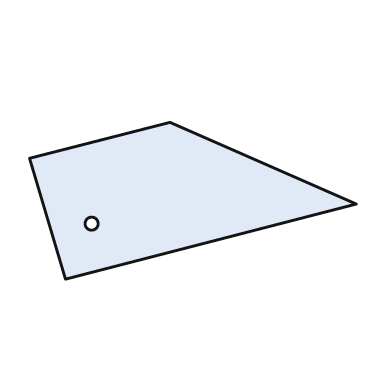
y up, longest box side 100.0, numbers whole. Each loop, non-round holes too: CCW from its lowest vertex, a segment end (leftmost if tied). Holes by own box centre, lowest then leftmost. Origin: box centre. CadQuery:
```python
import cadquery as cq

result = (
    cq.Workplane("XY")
    .moveTo(-39.0, -24.0)
    .lineTo(50.0, -1.0)
    .lineTo(-7.0, 24.0)
    .lineTo(-50.0, 13.0)
    .close()
    .moveTo(-31.0, -7.0)
    .circle(2.0)
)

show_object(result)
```